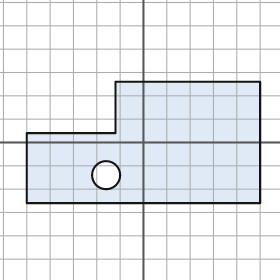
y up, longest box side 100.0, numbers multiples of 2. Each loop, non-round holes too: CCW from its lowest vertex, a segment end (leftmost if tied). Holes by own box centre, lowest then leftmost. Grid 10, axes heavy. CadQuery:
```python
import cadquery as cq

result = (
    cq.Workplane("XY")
    .moveTo(-50.0, -26.0)
    .lineTo(50.0, -26.0)
    .lineTo(50.0, 26.0)
    .lineTo(-12.0, 26.0)
    .lineTo(-12.0, 4.0)
    .lineTo(-50.0, 4.0)
    .close()
    .moveTo(-16.0, -14.0)
    .circle(6.0)
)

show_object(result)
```